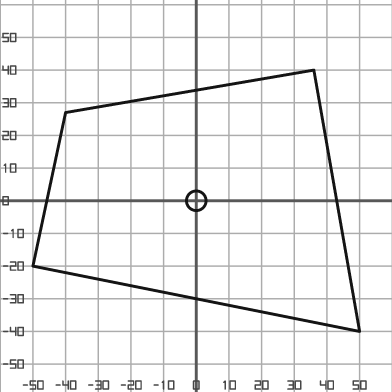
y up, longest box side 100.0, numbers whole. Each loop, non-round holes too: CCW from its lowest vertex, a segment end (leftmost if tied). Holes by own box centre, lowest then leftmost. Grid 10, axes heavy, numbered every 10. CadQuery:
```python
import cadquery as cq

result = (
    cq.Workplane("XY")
    .moveTo(50.0, -40.0)
    .lineTo(36.0, 40.0)
    .lineTo(-40.0, 27.0)
    .lineTo(-50.0, -20.0)
    .close()
    .moveTo(0.0, 0.0)
    .circle(3.0)
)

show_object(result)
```